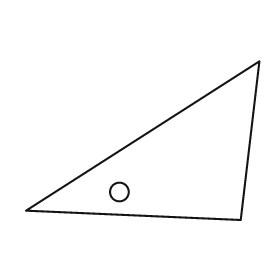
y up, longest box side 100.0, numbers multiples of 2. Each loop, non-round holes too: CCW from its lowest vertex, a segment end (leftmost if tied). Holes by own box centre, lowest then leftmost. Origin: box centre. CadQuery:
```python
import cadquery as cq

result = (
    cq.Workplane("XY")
    .moveTo(42.0, -34.0)
    .lineTo(50.0, 34.0)
    .lineTo(-50.0, -30.0)
    .close()
    .moveTo(-10.0, -22.0)
    .circle(4.0)
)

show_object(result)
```